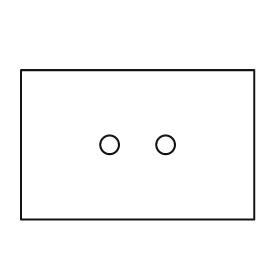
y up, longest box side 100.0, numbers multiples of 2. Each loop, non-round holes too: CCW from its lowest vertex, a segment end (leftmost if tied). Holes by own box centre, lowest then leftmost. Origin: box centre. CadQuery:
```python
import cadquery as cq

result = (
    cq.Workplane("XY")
    .moveTo(-50.0, -32.0)
    .lineTo(50.0, -32.0)
    .lineTo(50.0, 32.0)
    .lineTo(-50.0, 32.0)
    .close()
    .moveTo(-12.0, 0.0)
    .circle(4.0)
    .moveTo(12.0, 0.0)
    .circle(4.0)
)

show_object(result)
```